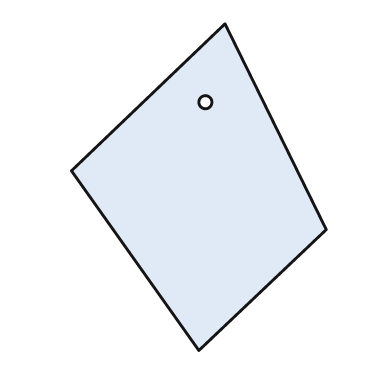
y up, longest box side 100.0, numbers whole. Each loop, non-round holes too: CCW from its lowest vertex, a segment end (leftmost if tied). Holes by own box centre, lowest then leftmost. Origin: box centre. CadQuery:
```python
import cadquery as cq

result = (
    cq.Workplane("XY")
    .moveTo(0.0, -50.0)
    .lineTo(39.0, -13.0)
    .lineTo(8.0, 50.0)
    .lineTo(-39.0, 5.0)
    .close()
    .moveTo(2.0, 26.0)
    .circle(2.0)
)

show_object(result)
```